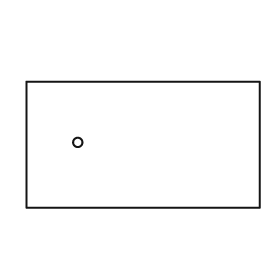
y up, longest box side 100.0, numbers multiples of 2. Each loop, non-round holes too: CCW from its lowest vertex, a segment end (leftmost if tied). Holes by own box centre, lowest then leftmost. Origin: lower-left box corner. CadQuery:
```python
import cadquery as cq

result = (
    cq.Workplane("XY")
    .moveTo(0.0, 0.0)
    .lineTo(100.0, 0.0)
    .lineTo(100.0, 54.0)
    .lineTo(0.0, 54.0)
    .close()
    .moveTo(22.0, 28.0)
    .circle(2.0)
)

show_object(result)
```